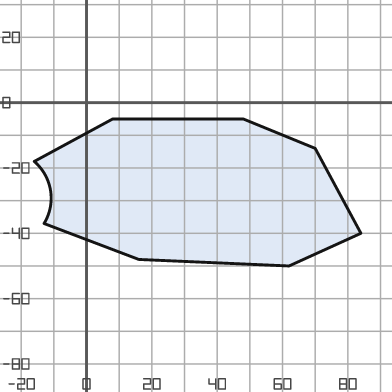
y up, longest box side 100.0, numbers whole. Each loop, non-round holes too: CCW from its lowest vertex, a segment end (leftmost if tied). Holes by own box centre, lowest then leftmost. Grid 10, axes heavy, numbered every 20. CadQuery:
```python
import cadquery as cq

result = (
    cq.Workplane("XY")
    .moveTo(62.0, -50.0)
    .lineTo(84.0, -40.0)
    .lineTo(70.0, -14.0)
    .lineTo(48.0, -5.0)
    .lineTo(8.0, -5.0)
    .lineTo(-16.0, -18.0)
    .threePointArc((-11.0, -27.0), (-13.0, -37.0))
    .lineTo(16.0, -48.0)
    .close()
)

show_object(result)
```